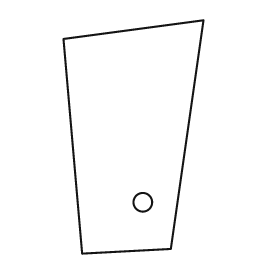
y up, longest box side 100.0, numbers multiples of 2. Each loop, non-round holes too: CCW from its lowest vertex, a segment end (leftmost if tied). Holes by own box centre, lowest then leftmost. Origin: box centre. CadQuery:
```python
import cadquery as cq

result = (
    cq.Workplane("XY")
    .moveTo(-22.0, -50.0)
    .lineTo(16.0, -48.0)
    .lineTo(30.0, 50.0)
    .lineTo(-30.0, 42.0)
    .close()
    .moveTo(4.0, -28.0)
    .circle(4.0)
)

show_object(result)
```